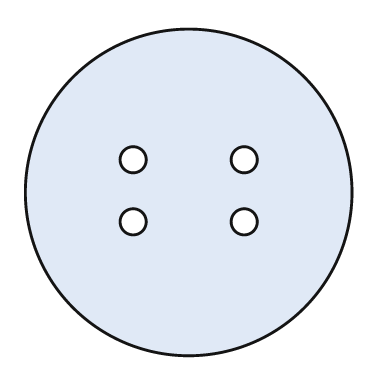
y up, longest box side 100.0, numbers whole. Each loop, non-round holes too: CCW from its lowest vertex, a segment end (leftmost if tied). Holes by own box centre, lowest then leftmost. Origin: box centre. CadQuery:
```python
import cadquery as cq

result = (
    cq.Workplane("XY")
    .moveTo(0.0, 0.0)
    .circle(50.0)
    .moveTo(-17.0, -9.0)
    .circle(4.0)
    .moveTo(17.0, -9.0)
    .circle(4.0)
    .moveTo(-17.0, 10.0)
    .circle(4.0)
    .moveTo(17.0, 10.0)
    .circle(4.0)
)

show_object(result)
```